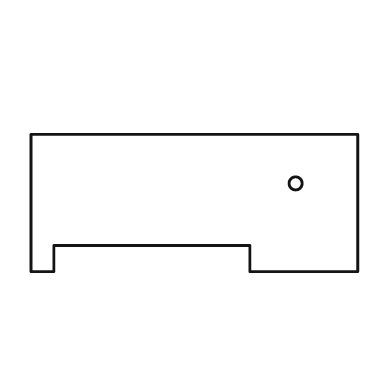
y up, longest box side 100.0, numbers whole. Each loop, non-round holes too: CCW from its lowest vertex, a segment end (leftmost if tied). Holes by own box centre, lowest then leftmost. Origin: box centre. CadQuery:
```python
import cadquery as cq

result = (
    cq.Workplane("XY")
    .moveTo(-50.0, -21.0)
    .lineTo(-43.0, -21.0)
    .lineTo(-43.0, -13.0)
    .lineTo(17.0, -13.0)
    .lineTo(17.0, -21.0)
    .lineTo(50.0, -21.0)
    .lineTo(50.0, 21.0)
    .lineTo(-50.0, 21.0)
    .close()
    .moveTo(31.0, 6.0)
    .circle(2.0)
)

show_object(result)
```